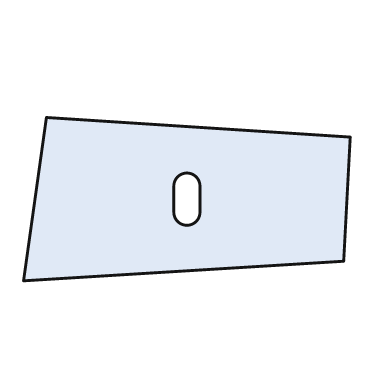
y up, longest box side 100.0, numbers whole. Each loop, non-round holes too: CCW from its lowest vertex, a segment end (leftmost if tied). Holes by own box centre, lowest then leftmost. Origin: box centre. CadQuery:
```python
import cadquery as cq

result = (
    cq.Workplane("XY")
    .moveTo(-50.0, -25.0)
    .lineTo(48.0, -19.0)
    .lineTo(50.0, 19.0)
    .lineTo(-43.0, 25.0)
    .close()
    .moveTo(-4.0, -4.0)
    .threePointArc((0.0, -8.0), (4.0, -4.0))
    .lineTo(4.0, 4.0)
    .threePointArc((0.0, 8.0), (-4.0, 4.0))
    .close()
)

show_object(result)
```